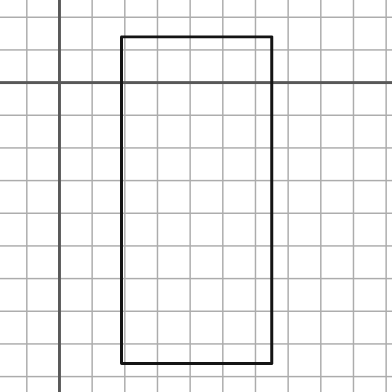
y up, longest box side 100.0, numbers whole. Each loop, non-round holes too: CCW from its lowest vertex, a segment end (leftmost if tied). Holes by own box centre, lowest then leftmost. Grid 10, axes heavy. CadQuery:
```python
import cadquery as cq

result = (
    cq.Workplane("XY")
    .moveTo(19.0, -86.0)
    .lineTo(65.0, -86.0)
    .lineTo(65.0, 14.0)
    .lineTo(19.0, 14.0)
    .close()
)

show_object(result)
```